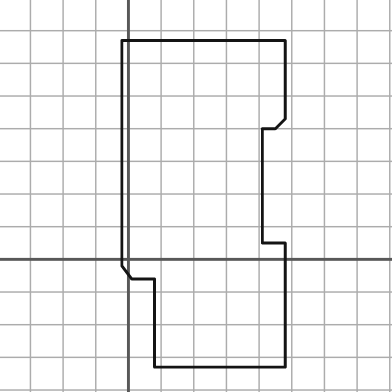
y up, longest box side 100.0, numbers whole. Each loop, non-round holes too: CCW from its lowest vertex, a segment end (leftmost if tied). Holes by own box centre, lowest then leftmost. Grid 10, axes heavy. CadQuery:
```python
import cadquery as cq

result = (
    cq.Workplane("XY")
    .moveTo(8.0, -33.0)
    .lineTo(48.0, -33.0)
    .lineTo(48.0, 5.0)
    .lineTo(41.0, 5.0)
    .lineTo(41.0, 40.0)
    .lineTo(45.0, 40.0)
    .lineTo(48.0, 43.0)
    .lineTo(48.0, 67.0)
    .lineTo(-2.0, 67.0)
    .lineTo(-2.0, -2.0)
    .lineTo(1.0, -6.0)
    .lineTo(8.0, -6.0)
    .close()
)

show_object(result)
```